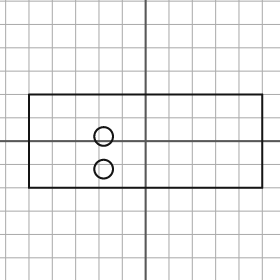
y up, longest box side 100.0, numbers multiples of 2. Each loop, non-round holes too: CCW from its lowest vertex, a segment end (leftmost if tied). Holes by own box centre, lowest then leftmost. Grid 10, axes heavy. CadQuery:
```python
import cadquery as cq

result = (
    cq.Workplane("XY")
    .moveTo(-50.0, -20.0)
    .lineTo(50.0, -20.0)
    .lineTo(50.0, 20.0)
    .lineTo(-50.0, 20.0)
    .close()
    .moveTo(-18.0, -12.0)
    .circle(4.0)
    .moveTo(-18.0, 2.0)
    .circle(4.0)
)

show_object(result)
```